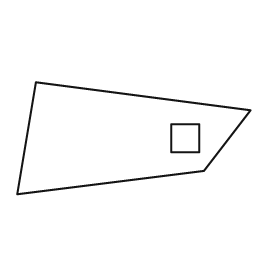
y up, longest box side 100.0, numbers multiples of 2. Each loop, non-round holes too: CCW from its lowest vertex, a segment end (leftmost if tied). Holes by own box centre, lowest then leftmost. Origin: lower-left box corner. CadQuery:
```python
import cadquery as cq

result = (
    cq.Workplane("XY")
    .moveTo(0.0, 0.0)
    .lineTo(80.0, 10.0)
    .lineTo(100.0, 36.0)
    .lineTo(8.0, 48.0)
    .close()
    .moveTo(66.0, 18.0)
    .lineTo(78.0, 18.0)
    .lineTo(78.0, 30.0)
    .lineTo(66.0, 30.0)
    .close()
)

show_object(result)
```